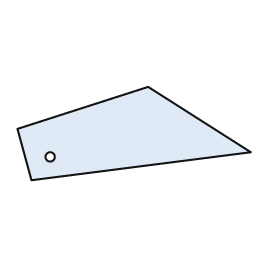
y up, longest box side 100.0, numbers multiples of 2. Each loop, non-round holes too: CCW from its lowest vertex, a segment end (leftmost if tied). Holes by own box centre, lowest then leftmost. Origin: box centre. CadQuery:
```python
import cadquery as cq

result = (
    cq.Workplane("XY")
    .moveTo(-44.0, -20.0)
    .lineTo(50.0, -8.0)
    .lineTo(6.0, 20.0)
    .lineTo(-50.0, 2.0)
    .close()
    .moveTo(-36.0, -10.0)
    .circle(2.0)
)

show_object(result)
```